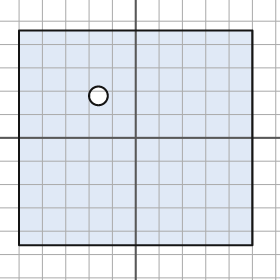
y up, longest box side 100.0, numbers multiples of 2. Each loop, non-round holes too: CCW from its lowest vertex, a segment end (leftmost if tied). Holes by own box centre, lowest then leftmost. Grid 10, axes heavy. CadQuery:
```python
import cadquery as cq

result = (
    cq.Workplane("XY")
    .moveTo(-50.0, -46.0)
    .lineTo(50.0, -46.0)
    .lineTo(50.0, 46.0)
    .lineTo(-50.0, 46.0)
    .close()
    .moveTo(-16.0, 18.0)
    .circle(4.0)
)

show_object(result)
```